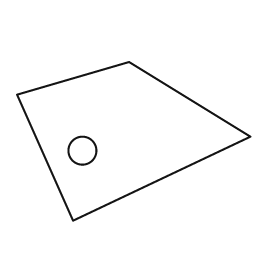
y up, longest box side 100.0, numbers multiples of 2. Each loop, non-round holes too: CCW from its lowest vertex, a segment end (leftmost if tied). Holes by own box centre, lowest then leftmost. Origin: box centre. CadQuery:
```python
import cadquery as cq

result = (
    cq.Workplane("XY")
    .moveTo(-26.0, -34.0)
    .lineTo(50.0, 2.0)
    .lineTo(-2.0, 34.0)
    .lineTo(-50.0, 20.0)
    .close()
    .moveTo(-22.0, -4.0)
    .circle(6.0)
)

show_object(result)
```